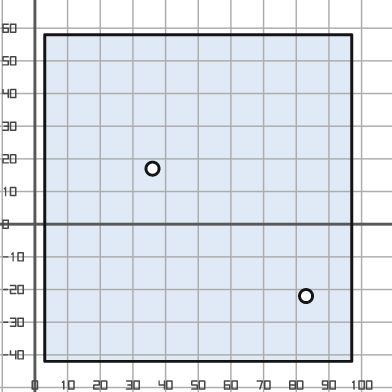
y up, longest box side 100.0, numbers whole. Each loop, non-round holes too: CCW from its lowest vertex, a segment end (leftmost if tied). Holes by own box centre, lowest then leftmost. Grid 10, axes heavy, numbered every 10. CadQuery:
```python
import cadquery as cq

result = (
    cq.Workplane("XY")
    .moveTo(3.0, -42.0)
    .lineTo(97.0, -42.0)
    .lineTo(97.0, 58.0)
    .lineTo(3.0, 58.0)
    .close()
    .moveTo(83.0, -22.0)
    .circle(2.0)
    .moveTo(36.0, 17.0)
    .circle(2.0)
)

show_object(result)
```